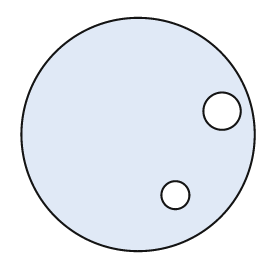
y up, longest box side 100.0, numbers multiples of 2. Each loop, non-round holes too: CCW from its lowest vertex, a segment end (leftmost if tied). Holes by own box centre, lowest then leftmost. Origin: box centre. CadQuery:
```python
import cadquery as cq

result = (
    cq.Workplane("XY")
    .moveTo(0.0, 0.0)
    .circle(50.0)
    .moveTo(16.0, -26.0)
    .circle(6.0)
    .moveTo(36.0, 10.0)
    .circle(8.0)
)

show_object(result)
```